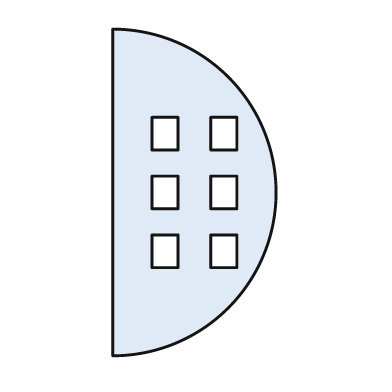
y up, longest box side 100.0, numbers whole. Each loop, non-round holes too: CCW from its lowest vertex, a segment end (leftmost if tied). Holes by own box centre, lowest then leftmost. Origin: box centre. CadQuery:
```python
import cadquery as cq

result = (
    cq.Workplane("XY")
    .moveTo(-25.0, -50.0)
    .threePointArc((25.0, 0.0), (-25.0, 50.0))
    .close()
    .moveTo(-13.0, -23.0)
    .lineTo(-5.0, -23.0)
    .lineTo(-5.0, -13.0)
    .lineTo(-13.0, -13.0)
    .close()
    .moveTo(5.0, -23.0)
    .lineTo(13.0, -23.0)
    .lineTo(13.0, -13.0)
    .lineTo(5.0, -13.0)
    .close()
    .moveTo(-13.0, -5.0)
    .lineTo(-5.0, -5.0)
    .lineTo(-5.0, 5.0)
    .lineTo(-13.0, 5.0)
    .close()
    .moveTo(5.0, -5.0)
    .lineTo(13.0, -5.0)
    .lineTo(13.0, 5.0)
    .lineTo(5.0, 5.0)
    .close()
    .moveTo(-13.0, 13.0)
    .lineTo(-5.0, 13.0)
    .lineTo(-5.0, 23.0)
    .lineTo(-13.0, 23.0)
    .close()
    .moveTo(5.0, 13.0)
    .lineTo(13.0, 13.0)
    .lineTo(13.0, 23.0)
    .lineTo(5.0, 23.0)
    .close()
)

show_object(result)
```